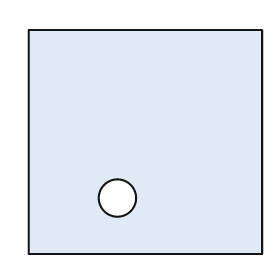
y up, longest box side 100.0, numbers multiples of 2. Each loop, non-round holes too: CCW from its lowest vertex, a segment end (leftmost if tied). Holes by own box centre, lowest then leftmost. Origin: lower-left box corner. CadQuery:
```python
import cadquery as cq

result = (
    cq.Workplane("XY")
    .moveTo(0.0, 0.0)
    .lineTo(100.0, 0.0)
    .lineTo(100.0, 96.0)
    .lineTo(0.0, 96.0)
    .close()
    .moveTo(38.0, 24.0)
    .circle(8.0)
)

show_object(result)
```